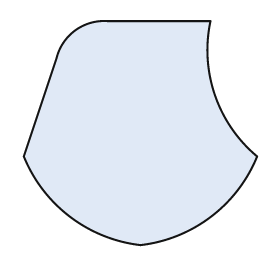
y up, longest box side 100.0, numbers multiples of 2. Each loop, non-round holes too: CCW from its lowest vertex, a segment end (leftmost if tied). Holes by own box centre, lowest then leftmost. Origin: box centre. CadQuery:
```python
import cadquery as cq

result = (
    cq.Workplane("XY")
    .moveTo(0.0, -48.0)
    .threePointArc((30.0, -36.0), (50.0, -10.0))
    .threePointArc((32.0, 16.0), (30.0, 48.0))
    .lineTo(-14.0, 48.0)
    .threePointArc((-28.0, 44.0), (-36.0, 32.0))
    .lineTo(-50.0, -10.0)
    .threePointArc((-30.0, -36.0), (0.0, -48.0))
    .close()
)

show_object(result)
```